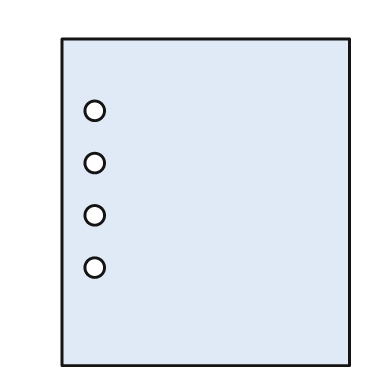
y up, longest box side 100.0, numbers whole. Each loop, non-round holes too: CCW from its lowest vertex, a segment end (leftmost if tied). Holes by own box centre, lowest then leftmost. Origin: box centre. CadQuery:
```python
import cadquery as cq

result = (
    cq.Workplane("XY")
    .moveTo(-44.0, -50.0)
    .lineTo(44.0, -50.0)
    .lineTo(44.0, 50.0)
    .lineTo(-44.0, 50.0)
    .close()
    .moveTo(-34.0, -20.0)
    .circle(3.0)
    .moveTo(-34.0, -4.0)
    .circle(3.0)
    .moveTo(-34.0, 12.0)
    .circle(3.0)
    .moveTo(-34.0, 28.0)
    .circle(3.0)
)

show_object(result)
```